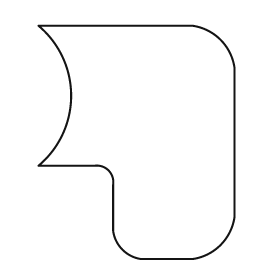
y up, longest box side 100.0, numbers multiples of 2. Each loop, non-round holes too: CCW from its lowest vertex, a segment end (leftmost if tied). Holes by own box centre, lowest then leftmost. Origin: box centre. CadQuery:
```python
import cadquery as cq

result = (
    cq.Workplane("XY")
    .moveTo(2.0, -50.0)
    .lineTo(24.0, -50.0)
    .threePointArc((36.0, -44.0), (42.0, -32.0))
    .lineTo(42.0, 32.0)
    .threePointArc((36.0, 44.0), (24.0, 50.0))
    .lineTo(-42.0, 50.0)
    .threePointArc((-28.0, 20.0), (-42.0, -10.0))
    .lineTo(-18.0, -10.0)
    .threePointArc((-12.0, -12.0), (-10.0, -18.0))
    .lineTo(-10.0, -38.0)
    .threePointArc((-6.0, -46.0), (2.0, -50.0))
    .close()
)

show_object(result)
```